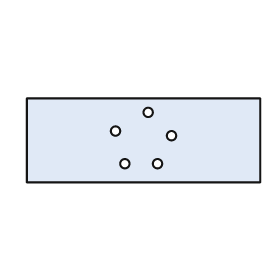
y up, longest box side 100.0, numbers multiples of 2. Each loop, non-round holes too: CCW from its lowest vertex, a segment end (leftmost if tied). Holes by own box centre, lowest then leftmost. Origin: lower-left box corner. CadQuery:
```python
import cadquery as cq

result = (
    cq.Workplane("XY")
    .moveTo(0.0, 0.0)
    .lineTo(100.0, 0.0)
    .lineTo(100.0, 36.0)
    .lineTo(0.0, 36.0)
    .close()
    .moveTo(42.0, 8.0)
    .circle(2.0)
    .moveTo(56.0, 8.0)
    .circle(2.0)
    .moveTo(62.0, 20.0)
    .circle(2.0)
    .moveTo(38.0, 22.0)
    .circle(2.0)
    .moveTo(52.0, 30.0)
    .circle(2.0)
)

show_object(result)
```